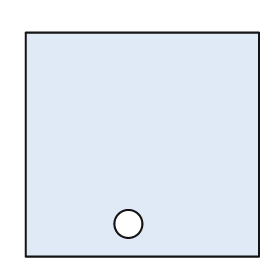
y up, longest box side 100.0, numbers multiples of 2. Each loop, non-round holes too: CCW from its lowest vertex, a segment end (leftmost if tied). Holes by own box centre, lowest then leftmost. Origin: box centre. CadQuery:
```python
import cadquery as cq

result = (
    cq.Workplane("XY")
    .moveTo(-50.0, -48.0)
    .lineTo(50.0, -48.0)
    .lineTo(50.0, 48.0)
    .lineTo(-50.0, 48.0)
    .close()
    .moveTo(-6.0, -34.0)
    .circle(6.0)
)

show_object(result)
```